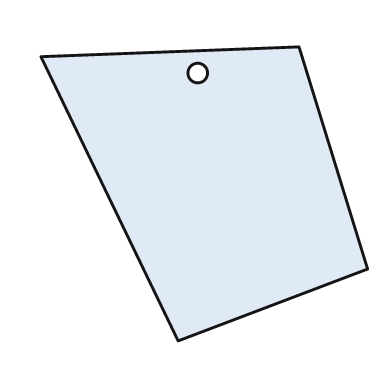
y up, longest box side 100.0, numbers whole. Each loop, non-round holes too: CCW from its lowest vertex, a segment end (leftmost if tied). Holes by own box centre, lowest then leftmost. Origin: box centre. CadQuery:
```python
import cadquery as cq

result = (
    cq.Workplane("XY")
    .moveTo(-8.0, -45.0)
    .lineTo(50.0, -23.0)
    .lineTo(29.0, 45.0)
    .lineTo(-50.0, 42.0)
    .close()
    .moveTo(-2.0, 37.0)
    .circle(3.0)
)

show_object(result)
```